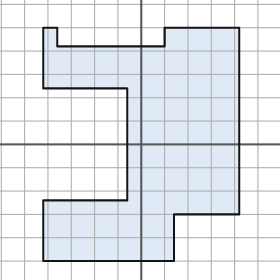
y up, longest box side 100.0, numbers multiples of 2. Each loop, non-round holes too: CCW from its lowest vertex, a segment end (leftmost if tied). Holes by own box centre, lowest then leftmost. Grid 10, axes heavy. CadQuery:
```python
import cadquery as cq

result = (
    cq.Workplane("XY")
    .moveTo(-42.0, -50.0)
    .lineTo(14.0, -50.0)
    .lineTo(14.0, -30.0)
    .lineTo(42.0, -30.0)
    .lineTo(42.0, 50.0)
    .lineTo(10.0, 50.0)
    .lineTo(10.0, 42.0)
    .lineTo(-36.0, 42.0)
    .lineTo(-36.0, 50.0)
    .lineTo(-42.0, 50.0)
    .lineTo(-42.0, 24.0)
    .lineTo(-6.0, 24.0)
    .lineTo(-6.0, -24.0)
    .lineTo(-42.0, -24.0)
    .close()
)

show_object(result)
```